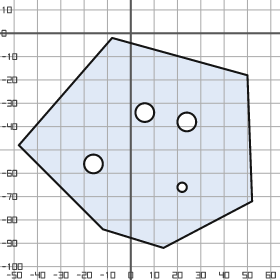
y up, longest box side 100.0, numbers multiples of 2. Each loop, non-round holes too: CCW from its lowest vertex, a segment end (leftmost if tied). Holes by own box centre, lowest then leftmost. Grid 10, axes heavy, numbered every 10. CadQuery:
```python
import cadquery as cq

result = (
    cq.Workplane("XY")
    .moveTo(14.0, -92.0)
    .lineTo(52.0, -72.0)
    .lineTo(50.0, -18.0)
    .lineTo(-8.0, -2.0)
    .lineTo(-48.0, -48.0)
    .lineTo(-12.0, -84.0)
    .close()
    .moveTo(22.0, -66.0)
    .circle(2.0)
    .moveTo(-16.0, -56.0)
    .circle(4.0)
    .moveTo(24.0, -38.0)
    .circle(4.0)
    .moveTo(6.0, -34.0)
    .circle(4.0)
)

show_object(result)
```